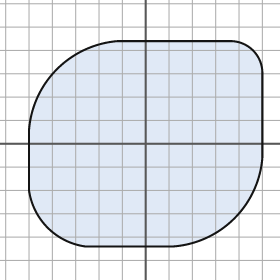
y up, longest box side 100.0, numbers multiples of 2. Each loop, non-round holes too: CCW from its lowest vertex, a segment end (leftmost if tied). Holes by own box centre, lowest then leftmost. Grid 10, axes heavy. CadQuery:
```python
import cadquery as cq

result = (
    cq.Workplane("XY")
    .moveTo(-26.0, -44.0)
    .lineTo(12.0, -44.0)
    .threePointArc((38.0, -32.0), (50.0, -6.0))
    .lineTo(50.0, 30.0)
    .threePointArc((46.0, 40.0), (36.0, 44.0))
    .lineTo(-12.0, 44.0)
    .threePointArc((-38.0, 32.0), (-50.0, 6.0))
    .lineTo(-50.0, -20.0)
    .threePointArc((-42.0, -36.0), (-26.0, -44.0))
    .close()
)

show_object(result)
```